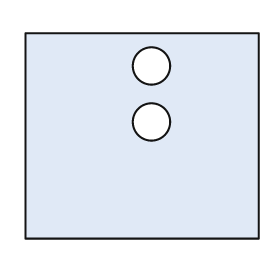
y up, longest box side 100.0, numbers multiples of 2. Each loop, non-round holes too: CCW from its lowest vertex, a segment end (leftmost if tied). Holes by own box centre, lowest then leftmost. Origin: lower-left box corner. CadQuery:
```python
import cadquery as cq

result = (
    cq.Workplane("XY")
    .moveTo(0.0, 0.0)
    .lineTo(100.0, 0.0)
    .lineTo(100.0, 88.0)
    .lineTo(0.0, 88.0)
    .close()
    .moveTo(54.0, 50.0)
    .circle(8.0)
    .moveTo(54.0, 74.0)
    .circle(8.0)
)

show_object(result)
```